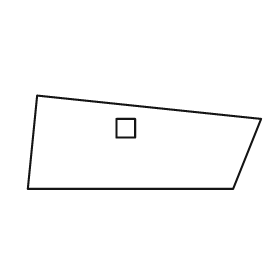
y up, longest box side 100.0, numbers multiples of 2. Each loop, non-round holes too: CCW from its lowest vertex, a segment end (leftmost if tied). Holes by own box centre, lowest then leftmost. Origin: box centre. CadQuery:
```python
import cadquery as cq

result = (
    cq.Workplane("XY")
    .moveTo(-50.0, -20.0)
    .lineTo(38.0, -20.0)
    .lineTo(50.0, 10.0)
    .lineTo(-46.0, 20.0)
    .close()
    .moveTo(-12.0, 2.0)
    .lineTo(-4.0, 2.0)
    .lineTo(-4.0, 10.0)
    .lineTo(-12.0, 10.0)
    .close()
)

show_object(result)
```